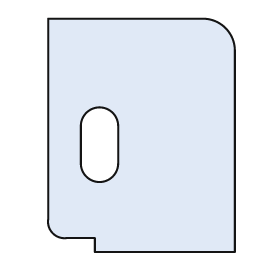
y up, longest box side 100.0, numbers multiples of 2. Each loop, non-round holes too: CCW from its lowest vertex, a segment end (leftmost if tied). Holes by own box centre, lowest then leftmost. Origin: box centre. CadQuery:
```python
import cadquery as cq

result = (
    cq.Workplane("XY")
    .moveTo(-20.0, -50.0)
    .lineTo(40.0, -50.0)
    .lineTo(40.0, 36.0)
    .threePointArc((36.0, 46.0), (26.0, 50.0))
    .lineTo(-40.0, 50.0)
    .lineTo(-40.0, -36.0)
    .threePointArc((-38.0, -42.0), (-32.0, -44.0))
    .lineTo(-20.0, -44.0)
    .close()
    .moveTo(-26.0, -12.0)
    .threePointArc((-18.0, -20.0), (-10.0, -12.0))
    .lineTo(-10.0, 4.0)
    .threePointArc((-18.0, 12.0), (-26.0, 4.0))
    .close()
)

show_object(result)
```